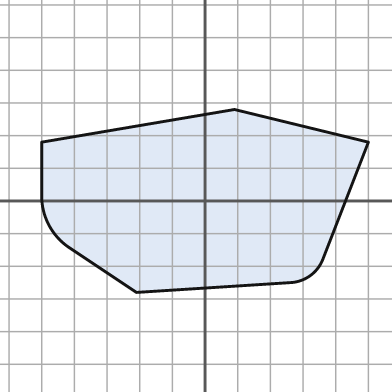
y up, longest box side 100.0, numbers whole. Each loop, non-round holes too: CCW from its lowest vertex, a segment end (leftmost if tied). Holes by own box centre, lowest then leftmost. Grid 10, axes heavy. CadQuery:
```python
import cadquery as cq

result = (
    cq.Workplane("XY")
    .moveTo(-21.0, -28.0)
    .lineTo(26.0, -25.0)
    .threePointArc((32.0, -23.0), (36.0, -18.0))
    .lineTo(50.0, 18.0)
    .lineTo(9.0, 28.0)
    .lineTo(-50.0, 18.0)
    .lineTo(-50.0, 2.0)
    .threePointArc((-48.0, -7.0), (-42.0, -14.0))
    .close()
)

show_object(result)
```